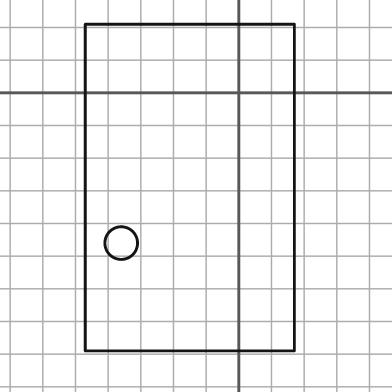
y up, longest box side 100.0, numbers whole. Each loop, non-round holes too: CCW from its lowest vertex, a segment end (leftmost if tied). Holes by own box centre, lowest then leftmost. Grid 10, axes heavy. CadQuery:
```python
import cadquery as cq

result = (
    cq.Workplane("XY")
    .moveTo(-47.0, -79.0)
    .lineTo(17.0, -79.0)
    .lineTo(17.0, 21.0)
    .lineTo(-47.0, 21.0)
    .close()
    .moveTo(-36.0, -46.0)
    .circle(5.0)
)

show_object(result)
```